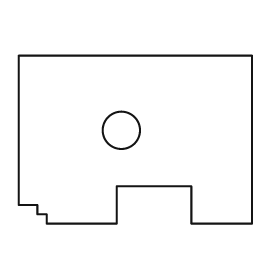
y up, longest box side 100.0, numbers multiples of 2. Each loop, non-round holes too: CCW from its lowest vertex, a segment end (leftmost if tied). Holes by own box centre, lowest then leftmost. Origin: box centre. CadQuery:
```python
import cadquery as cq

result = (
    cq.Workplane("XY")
    .moveTo(-38.0, -36.0)
    .lineTo(-8.0, -36.0)
    .lineTo(-8.0, -20.0)
    .lineTo(24.0, -20.0)
    .lineTo(24.0, -36.0)
    .lineTo(50.0, -36.0)
    .lineTo(50.0, 36.0)
    .lineTo(-50.0, 36.0)
    .lineTo(-50.0, -28.0)
    .lineTo(-42.0, -28.0)
    .lineTo(-42.0, -32.0)
    .lineTo(-38.0, -32.0)
    .close()
    .moveTo(-6.0, 4.0)
    .circle(8.0)
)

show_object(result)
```